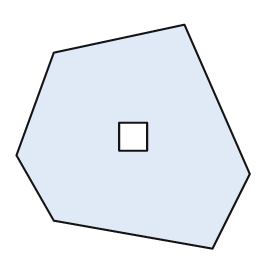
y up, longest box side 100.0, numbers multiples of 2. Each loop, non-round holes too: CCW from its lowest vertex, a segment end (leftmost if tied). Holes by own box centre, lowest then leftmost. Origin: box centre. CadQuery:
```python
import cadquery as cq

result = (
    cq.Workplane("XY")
    .moveTo(34.0, -48.0)
    .lineTo(50.0, -16.0)
    .lineTo(22.0, 48.0)
    .lineTo(-34.0, 36.0)
    .lineTo(-50.0, -8.0)
    .lineTo(-34.0, -36.0)
    .close()
    .moveTo(-6.0, -6.0)
    .lineTo(6.0, -6.0)
    .lineTo(6.0, 6.0)
    .lineTo(-6.0, 6.0)
    .close()
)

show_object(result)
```